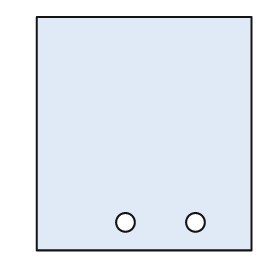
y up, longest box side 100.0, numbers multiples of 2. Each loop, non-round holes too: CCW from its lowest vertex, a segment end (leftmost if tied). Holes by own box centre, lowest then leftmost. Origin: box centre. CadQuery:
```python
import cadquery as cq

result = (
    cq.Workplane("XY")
    .moveTo(-46.0, -50.0)
    .lineTo(46.0, -50.0)
    .lineTo(46.0, 50.0)
    .lineTo(-46.0, 50.0)
    .close()
    .moveTo(-8.0, -38.0)
    .circle(4.0)
    .moveTo(22.0, -38.0)
    .circle(4.0)
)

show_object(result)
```